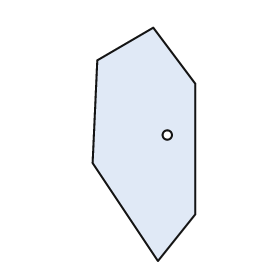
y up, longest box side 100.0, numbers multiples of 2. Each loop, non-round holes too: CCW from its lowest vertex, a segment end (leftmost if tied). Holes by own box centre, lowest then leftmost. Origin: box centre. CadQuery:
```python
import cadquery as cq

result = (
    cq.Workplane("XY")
    .moveTo(6.0, -50.0)
    .lineTo(22.0, -30.0)
    .lineTo(22.0, 26.0)
    .lineTo(4.0, 50.0)
    .lineTo(-20.0, 36.0)
    .lineTo(-22.0, -8.0)
    .close()
    .moveTo(10.0, 4.0)
    .circle(2.0)
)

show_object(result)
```